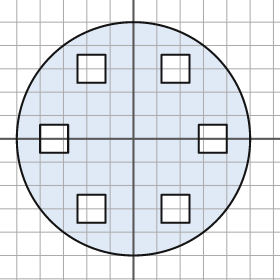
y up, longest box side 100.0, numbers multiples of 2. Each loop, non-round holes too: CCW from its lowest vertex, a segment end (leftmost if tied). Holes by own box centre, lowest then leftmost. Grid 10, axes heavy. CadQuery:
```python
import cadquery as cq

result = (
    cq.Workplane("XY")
    .moveTo(0.0, 0.0)
    .circle(50.0)
    .moveTo(-24.0, -36.0)
    .lineTo(-12.0, -36.0)
    .lineTo(-12.0, -24.0)
    .lineTo(-24.0, -24.0)
    .close()
    .moveTo(12.0, -36.0)
    .lineTo(24.0, -36.0)
    .lineTo(24.0, -24.0)
    .lineTo(12.0, -24.0)
    .close()
    .moveTo(-40.0, -6.0)
    .lineTo(-28.0, -6.0)
    .lineTo(-28.0, 6.0)
    .lineTo(-40.0, 6.0)
    .close()
    .moveTo(28.0, -6.0)
    .lineTo(40.0, -6.0)
    .lineTo(40.0, 6.0)
    .lineTo(28.0, 6.0)
    .close()
    .moveTo(-24.0, 24.0)
    .lineTo(-12.0, 24.0)
    .lineTo(-12.0, 36.0)
    .lineTo(-24.0, 36.0)
    .close()
    .moveTo(12.0, 24.0)
    .lineTo(24.0, 24.0)
    .lineTo(24.0, 36.0)
    .lineTo(12.0, 36.0)
    .close()
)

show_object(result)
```